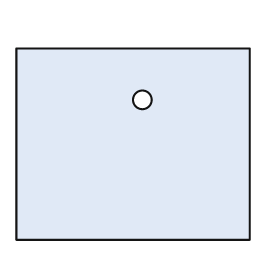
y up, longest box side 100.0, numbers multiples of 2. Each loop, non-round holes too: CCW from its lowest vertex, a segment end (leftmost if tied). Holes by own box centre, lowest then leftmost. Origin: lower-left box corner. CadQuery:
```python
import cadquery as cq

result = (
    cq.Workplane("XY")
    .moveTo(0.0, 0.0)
    .lineTo(100.0, 0.0)
    .lineTo(100.0, 82.0)
    .lineTo(0.0, 82.0)
    .close()
    .moveTo(54.0, 60.0)
    .circle(4.0)
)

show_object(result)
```